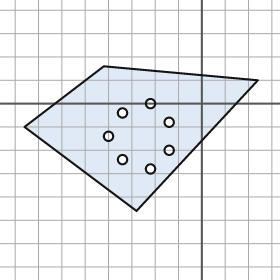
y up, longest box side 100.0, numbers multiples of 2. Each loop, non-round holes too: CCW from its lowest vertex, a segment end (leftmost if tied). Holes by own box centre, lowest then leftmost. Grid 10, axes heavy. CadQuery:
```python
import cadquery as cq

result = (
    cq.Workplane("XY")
    .moveTo(-28.0, -46.0)
    .lineTo(24.0, 10.0)
    .lineTo(-42.0, 16.0)
    .lineTo(-76.0, -10.0)
    .close()
    .moveTo(-22.0, -28.0)
    .circle(2.0)
    .moveTo(-34.0, -24.0)
    .circle(2.0)
    .moveTo(-14.0, -20.0)
    .circle(2.0)
    .moveTo(-40.0, -14.0)
    .circle(2.0)
    .moveTo(-14.0, -8.0)
    .circle(2.0)
    .moveTo(-34.0, -4.0)
    .circle(2.0)
    .moveTo(-22.0, 0.0)
    .circle(2.0)
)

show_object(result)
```